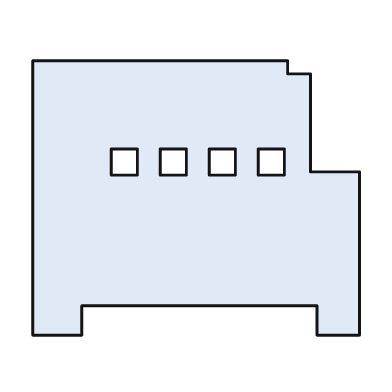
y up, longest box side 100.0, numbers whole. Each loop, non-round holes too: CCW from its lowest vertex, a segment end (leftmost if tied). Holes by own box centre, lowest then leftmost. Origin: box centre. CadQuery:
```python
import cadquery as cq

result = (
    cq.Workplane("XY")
    .moveTo(-50.0, -42.0)
    .lineTo(-35.0, -42.0)
    .lineTo(-35.0, -33.0)
    .lineTo(37.0, -33.0)
    .lineTo(37.0, -42.0)
    .lineTo(50.0, -42.0)
    .lineTo(50.0, 8.0)
    .lineTo(35.0, 8.0)
    .lineTo(35.0, 38.0)
    .lineTo(28.0, 38.0)
    .lineTo(28.0, 42.0)
    .lineTo(-50.0, 42.0)
    .close()
    .moveTo(-26.0, 7.0)
    .lineTo(-18.0, 7.0)
    .lineTo(-18.0, 15.0)
    .lineTo(-26.0, 15.0)
    .close()
    .moveTo(-11.0, 7.0)
    .lineTo(-3.0, 7.0)
    .lineTo(-3.0, 15.0)
    .lineTo(-11.0, 15.0)
    .close()
    .moveTo(4.0, 7.0)
    .lineTo(12.0, 7.0)
    .lineTo(12.0, 15.0)
    .lineTo(4.0, 15.0)
    .close()
    .moveTo(19.0, 7.0)
    .lineTo(27.0, 7.0)
    .lineTo(27.0, 15.0)
    .lineTo(19.0, 15.0)
    .close()
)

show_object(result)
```